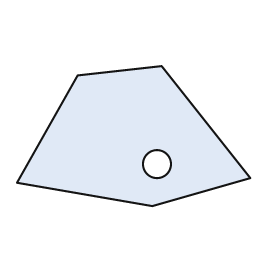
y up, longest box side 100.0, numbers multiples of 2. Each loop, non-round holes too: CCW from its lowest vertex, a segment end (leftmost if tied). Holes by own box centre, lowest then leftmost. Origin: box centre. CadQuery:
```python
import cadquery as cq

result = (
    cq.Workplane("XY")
    .moveTo(8.0, -30.0)
    .lineTo(50.0, -18.0)
    .lineTo(12.0, 30.0)
    .lineTo(-24.0, 26.0)
    .lineTo(-50.0, -20.0)
    .close()
    .moveTo(10.0, -12.0)
    .circle(6.0)
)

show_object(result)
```